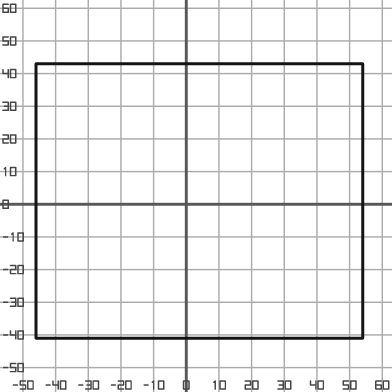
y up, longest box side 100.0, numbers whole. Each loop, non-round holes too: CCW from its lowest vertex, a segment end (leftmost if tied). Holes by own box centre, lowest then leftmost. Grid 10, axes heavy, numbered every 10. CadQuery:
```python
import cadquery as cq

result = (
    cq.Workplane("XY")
    .moveTo(-46.0, -41.0)
    .lineTo(54.0, -41.0)
    .lineTo(54.0, 43.0)
    .lineTo(-46.0, 43.0)
    .close()
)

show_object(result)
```